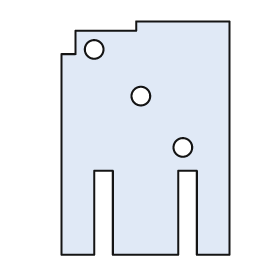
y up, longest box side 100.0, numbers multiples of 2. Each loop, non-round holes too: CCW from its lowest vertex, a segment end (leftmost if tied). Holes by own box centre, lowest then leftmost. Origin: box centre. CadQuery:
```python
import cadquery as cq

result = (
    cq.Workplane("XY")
    .moveTo(-36.0, -50.0)
    .lineTo(-22.0, -50.0)
    .lineTo(-22.0, -14.0)
    .lineTo(-14.0, -14.0)
    .lineTo(-14.0, -50.0)
    .lineTo(14.0, -50.0)
    .lineTo(14.0, -14.0)
    .lineTo(22.0, -14.0)
    .lineTo(22.0, -50.0)
    .lineTo(36.0, -50.0)
    .lineTo(36.0, 50.0)
    .lineTo(-4.0, 50.0)
    .lineTo(-4.0, 46.0)
    .lineTo(-30.0, 46.0)
    .lineTo(-30.0, 36.0)
    .lineTo(-36.0, 36.0)
    .close()
    .moveTo(16.0, -4.0)
    .circle(4.0)
    .moveTo(-2.0, 18.0)
    .circle(4.0)
    .moveTo(-22.0, 38.0)
    .circle(4.0)
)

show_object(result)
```